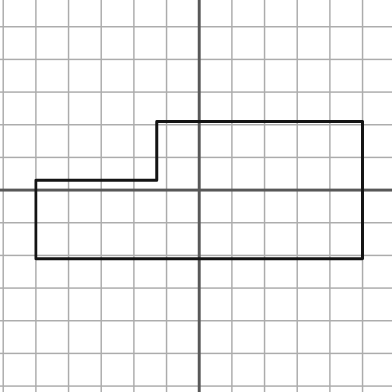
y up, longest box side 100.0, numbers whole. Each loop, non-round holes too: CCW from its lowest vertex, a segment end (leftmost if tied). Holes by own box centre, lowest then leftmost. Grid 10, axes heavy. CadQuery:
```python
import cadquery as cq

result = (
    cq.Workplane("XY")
    .moveTo(-50.0, -21.0)
    .lineTo(50.0, -21.0)
    .lineTo(50.0, 21.0)
    .lineTo(-13.0, 21.0)
    .lineTo(-13.0, 3.0)
    .lineTo(-50.0, 3.0)
    .close()
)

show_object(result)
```